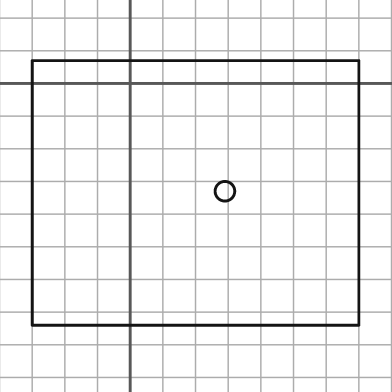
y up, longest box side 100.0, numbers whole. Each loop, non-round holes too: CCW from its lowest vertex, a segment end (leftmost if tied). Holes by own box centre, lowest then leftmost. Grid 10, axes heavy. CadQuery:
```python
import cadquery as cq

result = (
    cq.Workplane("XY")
    .moveTo(-30.0, -74.0)
    .lineTo(70.0, -74.0)
    .lineTo(70.0, 7.0)
    .lineTo(-30.0, 7.0)
    .close()
    .moveTo(29.0, -33.0)
    .circle(3.0)
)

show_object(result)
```